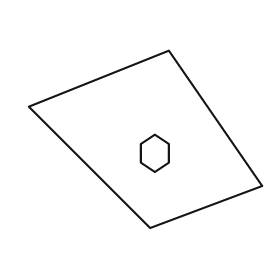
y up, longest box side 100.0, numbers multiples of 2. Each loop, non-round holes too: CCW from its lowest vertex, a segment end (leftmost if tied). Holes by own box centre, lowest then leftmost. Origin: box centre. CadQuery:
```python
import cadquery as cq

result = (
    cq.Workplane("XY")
    .moveTo(2.0, -38.0)
    .lineTo(50.0, -20.0)
    .lineTo(10.0, 38.0)
    .lineTo(-50.0, 14.0)
    .close()
    .moveTo(4.0, -14.0)
    .lineTo(10.0, -10.0)
    .lineTo(10.0, -2.0)
    .lineTo(4.0, 2.0)
    .lineTo(-2.0, -2.0)
    .lineTo(-2.0, -10.0)
    .close()
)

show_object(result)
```